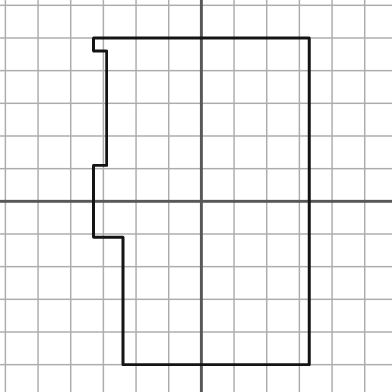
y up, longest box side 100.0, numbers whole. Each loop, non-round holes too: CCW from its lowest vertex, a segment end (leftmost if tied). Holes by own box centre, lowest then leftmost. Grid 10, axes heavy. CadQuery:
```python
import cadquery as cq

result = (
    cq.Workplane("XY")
    .moveTo(-24.0, -50.0)
    .lineTo(33.0, -50.0)
    .lineTo(33.0, 50.0)
    .lineTo(-33.0, 50.0)
    .lineTo(-33.0, 46.0)
    .lineTo(-29.0, 46.0)
    .lineTo(-29.0, 11.0)
    .lineTo(-33.0, 11.0)
    .lineTo(-33.0, -11.0)
    .lineTo(-24.0, -11.0)
    .close()
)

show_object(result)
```